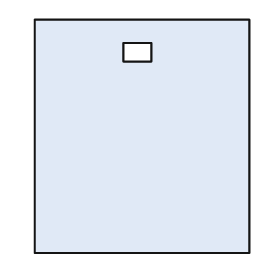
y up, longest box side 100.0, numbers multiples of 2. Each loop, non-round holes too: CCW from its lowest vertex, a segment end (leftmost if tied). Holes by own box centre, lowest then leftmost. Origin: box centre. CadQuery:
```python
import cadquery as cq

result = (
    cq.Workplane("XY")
    .moveTo(-46.0, -50.0)
    .lineTo(46.0, -50.0)
    .lineTo(46.0, 50.0)
    .lineTo(-46.0, 50.0)
    .close()
    .moveTo(-8.0, 32.0)
    .lineTo(4.0, 32.0)
    .lineTo(4.0, 40.0)
    .lineTo(-8.0, 40.0)
    .close()
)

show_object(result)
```